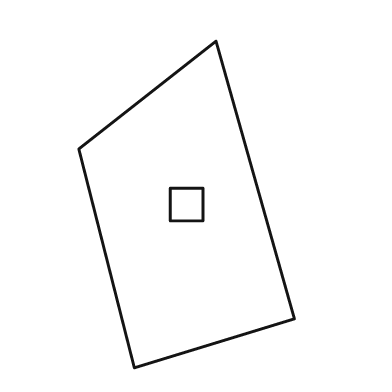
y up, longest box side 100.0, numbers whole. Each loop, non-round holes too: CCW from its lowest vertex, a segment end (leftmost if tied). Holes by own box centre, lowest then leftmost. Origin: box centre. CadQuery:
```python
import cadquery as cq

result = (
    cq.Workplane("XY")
    .moveTo(-16.0, -50.0)
    .lineTo(33.0, -35.0)
    .lineTo(9.0, 50.0)
    .lineTo(-33.0, 17.0)
    .close()
    .moveTo(-5.0, -5.0)
    .lineTo(5.0, -5.0)
    .lineTo(5.0, 5.0)
    .lineTo(-5.0, 5.0)
    .close()
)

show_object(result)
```